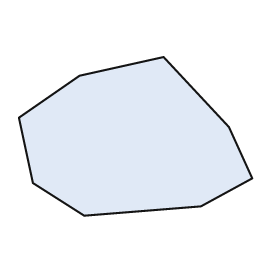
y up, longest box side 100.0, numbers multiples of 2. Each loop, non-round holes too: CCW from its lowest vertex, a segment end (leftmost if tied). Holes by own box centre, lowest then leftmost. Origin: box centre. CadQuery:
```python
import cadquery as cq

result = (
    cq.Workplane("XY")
    .moveTo(-22.0, -34.0)
    .lineTo(28.0, -30.0)
    .lineTo(50.0, -18.0)
    .lineTo(40.0, 4.0)
    .lineTo(12.0, 34.0)
    .lineTo(-24.0, 26.0)
    .lineTo(-50.0, 8.0)
    .lineTo(-44.0, -20.0)
    .close()
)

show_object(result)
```